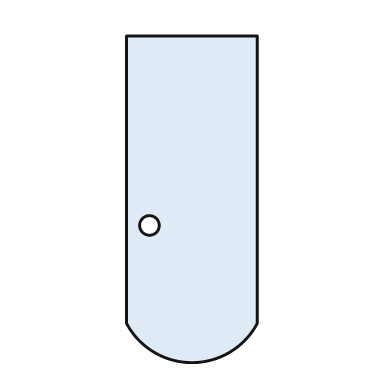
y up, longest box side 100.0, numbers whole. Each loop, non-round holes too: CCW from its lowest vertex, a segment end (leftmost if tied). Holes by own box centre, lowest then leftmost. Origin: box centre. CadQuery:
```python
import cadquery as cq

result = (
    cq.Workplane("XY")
    .moveTo(-20.0, -38.0)
    .threePointArc((0.0, -50.0), (20.0, -38.0))
    .lineTo(20.0, 50.0)
    .lineTo(-20.0, 50.0)
    .close()
    .moveTo(-13.0, -8.0)
    .circle(3.0)
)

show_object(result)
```